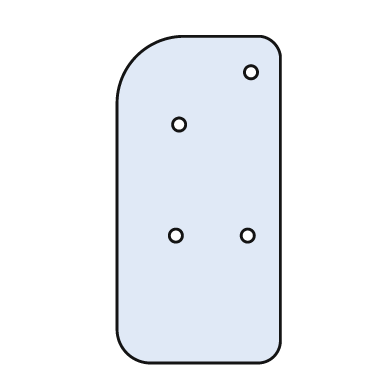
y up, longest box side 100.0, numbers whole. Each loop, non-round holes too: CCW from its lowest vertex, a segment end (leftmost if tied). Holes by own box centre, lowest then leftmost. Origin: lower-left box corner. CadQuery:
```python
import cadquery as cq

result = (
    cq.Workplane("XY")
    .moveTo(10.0, 0.0)
    .lineTo(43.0, 0.0)
    .threePointArc((48.0, 2.0), (50.0, 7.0))
    .lineTo(50.0, 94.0)
    .threePointArc((48.0, 98.0), (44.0, 100.0))
    .lineTo(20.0, 100.0)
    .threePointArc((6.0, 94.0), (0.0, 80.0))
    .lineTo(0.0, 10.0)
    .threePointArc((3.0, 3.0), (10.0, 0.0))
    .close()
    .moveTo(18.0, 39.0)
    .circle(2.0)
    .moveTo(40.0, 39.0)
    .circle(2.0)
    .moveTo(19.0, 73.0)
    .circle(2.0)
    .moveTo(41.0, 89.0)
    .circle(2.0)
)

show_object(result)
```